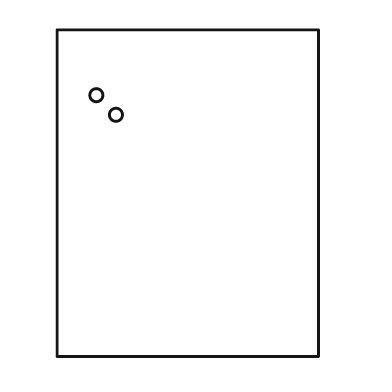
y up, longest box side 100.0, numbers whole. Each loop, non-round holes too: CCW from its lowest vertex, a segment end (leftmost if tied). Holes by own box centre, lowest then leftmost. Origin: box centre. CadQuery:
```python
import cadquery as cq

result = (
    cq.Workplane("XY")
    .moveTo(-40.0, -50.0)
    .lineTo(40.0, -50.0)
    .lineTo(40.0, 50.0)
    .lineTo(-40.0, 50.0)
    .close()
    .moveTo(-22.0, 24.0)
    .circle(2.0)
    .moveTo(-28.0, 30.0)
    .circle(2.0)
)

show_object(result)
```